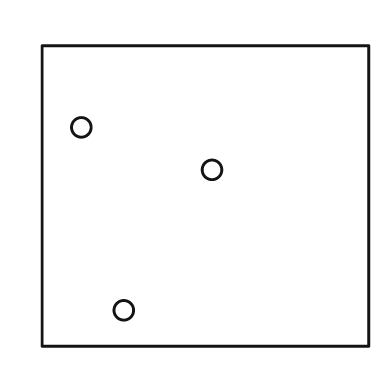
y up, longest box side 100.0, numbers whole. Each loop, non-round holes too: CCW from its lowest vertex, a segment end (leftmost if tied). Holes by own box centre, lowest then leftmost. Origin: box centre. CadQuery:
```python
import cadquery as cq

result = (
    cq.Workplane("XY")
    .moveTo(-50.0, -46.0)
    .lineTo(50.0, -46.0)
    .lineTo(50.0, 46.0)
    .lineTo(-50.0, 46.0)
    .close()
    .moveTo(-25.0, -35.0)
    .circle(3.0)
    .moveTo(2.0, 8.0)
    .circle(3.0)
    .moveTo(-38.0, 21.0)
    .circle(3.0)
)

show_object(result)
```